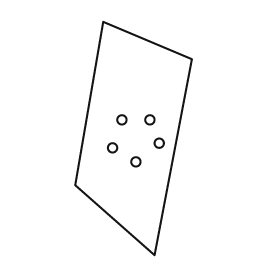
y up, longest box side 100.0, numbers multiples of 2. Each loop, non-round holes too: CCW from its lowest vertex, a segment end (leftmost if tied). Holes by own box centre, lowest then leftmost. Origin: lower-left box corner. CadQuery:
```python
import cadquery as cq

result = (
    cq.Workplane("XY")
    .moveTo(34.0, 0.0)
    .lineTo(50.0, 84.0)
    .lineTo(12.0, 100.0)
    .lineTo(0.0, 30.0)
    .close()
    .moveTo(26.0, 40.0)
    .circle(2.0)
    .moveTo(16.0, 46.0)
    .circle(2.0)
    .moveTo(36.0, 48.0)
    .circle(2.0)
    .moveTo(20.0, 58.0)
    .circle(2.0)
    .moveTo(32.0, 58.0)
    .circle(2.0)
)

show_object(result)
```